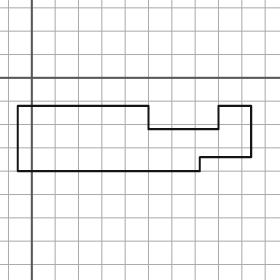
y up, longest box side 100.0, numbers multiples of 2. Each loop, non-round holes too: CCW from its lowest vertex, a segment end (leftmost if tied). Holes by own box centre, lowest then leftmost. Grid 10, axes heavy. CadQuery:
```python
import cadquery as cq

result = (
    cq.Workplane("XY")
    .moveTo(-6.0, -40.0)
    .lineTo(72.0, -40.0)
    .lineTo(72.0, -34.0)
    .lineTo(94.0, -34.0)
    .lineTo(94.0, -12.0)
    .lineTo(80.0, -12.0)
    .lineTo(80.0, -22.0)
    .lineTo(50.0, -22.0)
    .lineTo(50.0, -12.0)
    .lineTo(-6.0, -12.0)
    .close()
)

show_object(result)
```